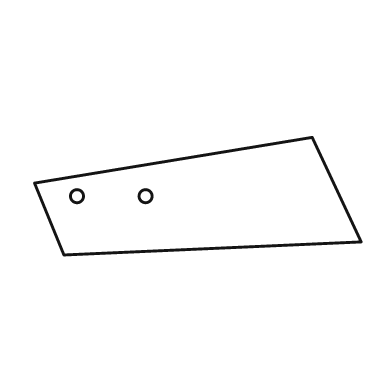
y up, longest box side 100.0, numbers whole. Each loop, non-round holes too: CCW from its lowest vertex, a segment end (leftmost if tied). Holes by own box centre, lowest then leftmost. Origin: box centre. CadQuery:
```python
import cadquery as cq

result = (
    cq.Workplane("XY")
    .moveTo(-41.0, -18.0)
    .lineTo(50.0, -14.0)
    .lineTo(35.0, 18.0)
    .lineTo(-50.0, 4.0)
    .close()
    .moveTo(-37.0, 0.0)
    .circle(2.0)
    .moveTo(-16.0, 0.0)
    .circle(2.0)
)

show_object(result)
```